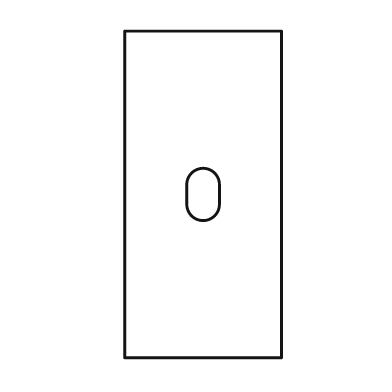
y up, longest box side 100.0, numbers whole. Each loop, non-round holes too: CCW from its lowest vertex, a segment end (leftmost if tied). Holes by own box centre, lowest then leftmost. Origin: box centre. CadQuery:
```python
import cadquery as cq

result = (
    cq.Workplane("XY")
    .moveTo(-24.0, -50.0)
    .lineTo(24.0, -50.0)
    .lineTo(24.0, 50.0)
    .lineTo(-24.0, 50.0)
    .close()
    .moveTo(-5.0, -3.0)
    .threePointArc((0.0, -8.0), (5.0, -3.0))
    .lineTo(5.0, 3.0)
    .threePointArc((0.0, 8.0), (-5.0, 3.0))
    .close()
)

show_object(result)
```